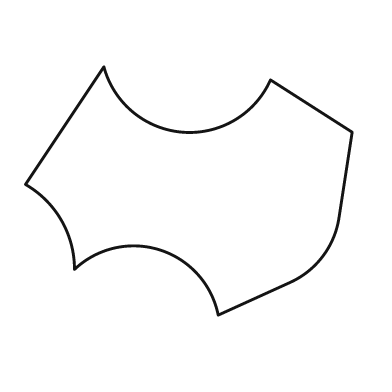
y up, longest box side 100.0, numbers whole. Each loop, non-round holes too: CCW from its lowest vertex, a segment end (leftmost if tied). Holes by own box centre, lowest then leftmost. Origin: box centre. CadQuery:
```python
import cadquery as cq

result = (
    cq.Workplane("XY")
    .moveTo(9.0, -38.0)
    .lineTo(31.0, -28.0)
    .threePointArc((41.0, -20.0), (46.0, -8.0))
    .lineTo(50.0, 18.0)
    .lineTo(25.0, 34.0)
    .threePointArc((-2.0, 18.0), (-26.0, 38.0))
    .lineTo(-50.0, 2.0)
    .threePointArc((-39.0, -9.0), (-35.0, -24.0))
    .threePointArc((-9.0, -18.0), (9.0, -38.0))
    .close()
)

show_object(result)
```